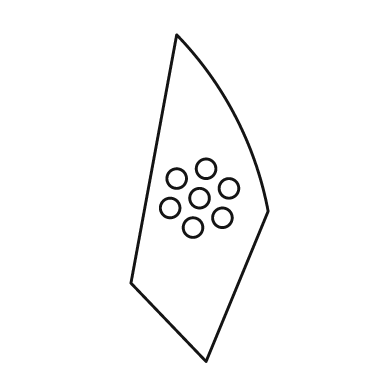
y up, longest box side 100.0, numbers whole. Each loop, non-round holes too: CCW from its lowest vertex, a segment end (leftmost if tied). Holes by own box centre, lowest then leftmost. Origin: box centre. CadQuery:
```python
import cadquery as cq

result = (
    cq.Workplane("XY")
    .moveTo(2.0, -50.0)
    .lineTo(21.0, -4.0)
    .threePointArc((11.0, 25.0), (-7.0, 50.0))
    .lineTo(-21.0, -26.0)
    .close()
    .moveTo(-2.0, -9.0)
    .circle(3.0)
    .moveTo(7.0, -6.0)
    .circle(3.0)
    .moveTo(-9.0, -3.0)
    .circle(3.0)
    .moveTo(0.0, 0.0)
    .circle(3.0)
    .moveTo(9.0, 3.0)
    .circle(3.0)
    .moveTo(-7.0, 6.0)
    .circle(3.0)
    .moveTo(2.0, 9.0)
    .circle(3.0)
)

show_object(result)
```